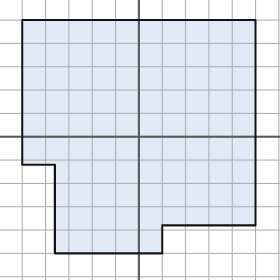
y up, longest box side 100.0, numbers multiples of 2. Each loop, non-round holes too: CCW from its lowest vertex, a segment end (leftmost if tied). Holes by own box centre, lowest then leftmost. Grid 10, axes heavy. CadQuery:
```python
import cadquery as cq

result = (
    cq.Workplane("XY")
    .moveTo(-36.0, -50.0)
    .lineTo(10.0, -50.0)
    .lineTo(10.0, -38.0)
    .lineTo(50.0, -38.0)
    .lineTo(50.0, 50.0)
    .lineTo(-50.0, 50.0)
    .lineTo(-50.0, -12.0)
    .lineTo(-36.0, -12.0)
    .close()
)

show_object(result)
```